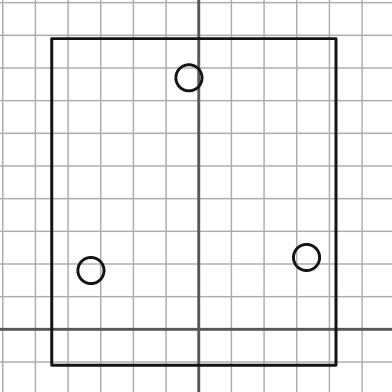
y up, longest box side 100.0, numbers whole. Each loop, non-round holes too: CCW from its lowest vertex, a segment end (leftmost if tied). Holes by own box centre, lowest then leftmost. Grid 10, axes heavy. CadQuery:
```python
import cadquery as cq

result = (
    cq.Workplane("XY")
    .moveTo(-45.0, -11.0)
    .lineTo(42.0, -11.0)
    .lineTo(42.0, 89.0)
    .lineTo(-45.0, 89.0)
    .close()
    .moveTo(-33.0, 18.0)
    .circle(4.0)
    .moveTo(33.0, 22.0)
    .circle(4.0)
    .moveTo(-3.0, 77.0)
    .circle(4.0)
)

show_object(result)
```